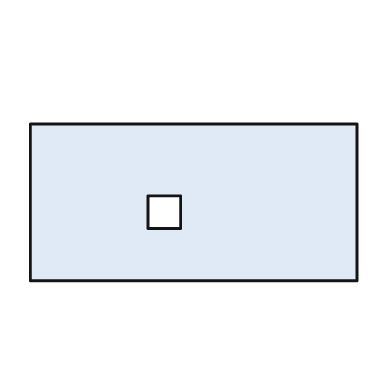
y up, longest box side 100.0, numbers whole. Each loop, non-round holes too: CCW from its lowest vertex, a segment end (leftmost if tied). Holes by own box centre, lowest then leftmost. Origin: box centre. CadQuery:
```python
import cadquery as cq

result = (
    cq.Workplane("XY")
    .moveTo(-50.0, -24.0)
    .lineTo(50.0, -24.0)
    .lineTo(50.0, 24.0)
    .lineTo(-50.0, 24.0)
    .close()
    .moveTo(-14.0, -8.0)
    .lineTo(-4.0, -8.0)
    .lineTo(-4.0, 2.0)
    .lineTo(-14.0, 2.0)
    .close()
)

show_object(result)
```